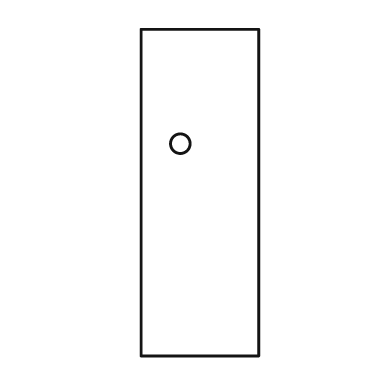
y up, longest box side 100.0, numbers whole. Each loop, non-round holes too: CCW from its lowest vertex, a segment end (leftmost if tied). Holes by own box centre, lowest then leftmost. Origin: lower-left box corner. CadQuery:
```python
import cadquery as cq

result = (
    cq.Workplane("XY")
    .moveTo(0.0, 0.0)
    .lineTo(36.0, 0.0)
    .lineTo(36.0, 100.0)
    .lineTo(0.0, 100.0)
    .close()
    .moveTo(12.0, 65.0)
    .circle(3.0)
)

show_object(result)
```